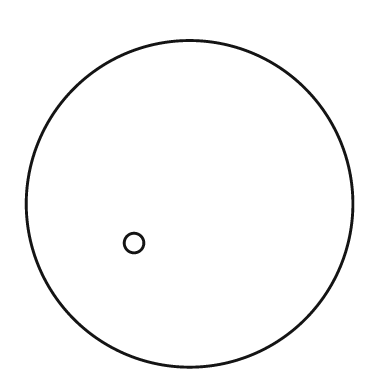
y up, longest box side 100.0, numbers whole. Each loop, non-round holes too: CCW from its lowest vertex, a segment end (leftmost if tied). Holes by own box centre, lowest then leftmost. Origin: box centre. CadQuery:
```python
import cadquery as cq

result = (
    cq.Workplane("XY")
    .moveTo(0.0, 0.0)
    .circle(50.0)
    .moveTo(-17.0, -12.0)
    .circle(3.0)
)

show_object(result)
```